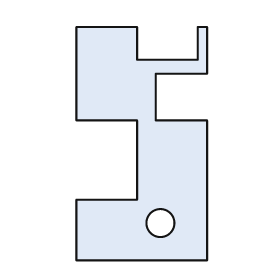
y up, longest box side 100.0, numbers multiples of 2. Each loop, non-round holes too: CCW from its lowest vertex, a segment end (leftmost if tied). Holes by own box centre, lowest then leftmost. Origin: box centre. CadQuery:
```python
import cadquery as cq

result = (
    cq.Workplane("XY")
    .moveTo(-28.0, -50.0)
    .lineTo(28.0, -50.0)
    .lineTo(28.0, 10.0)
    .lineTo(6.0, 10.0)
    .lineTo(6.0, 30.0)
    .lineTo(28.0, 30.0)
    .lineTo(28.0, 50.0)
    .lineTo(24.0, 50.0)
    .lineTo(24.0, 36.0)
    .lineTo(-2.0, 36.0)
    .lineTo(-2.0, 50.0)
    .lineTo(-28.0, 50.0)
    .lineTo(-28.0, 10.0)
    .lineTo(-2.0, 10.0)
    .lineTo(-2.0, -24.0)
    .lineTo(-28.0, -24.0)
    .close()
    .moveTo(8.0, -34.0)
    .circle(6.0)
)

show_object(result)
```